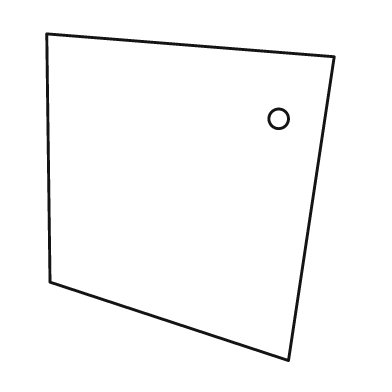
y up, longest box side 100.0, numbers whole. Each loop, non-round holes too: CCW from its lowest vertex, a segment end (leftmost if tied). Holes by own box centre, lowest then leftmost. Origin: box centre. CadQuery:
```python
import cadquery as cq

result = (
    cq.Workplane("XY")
    .moveTo(30.0, -50.0)
    .lineTo(44.0, 43.0)
    .lineTo(-44.0, 50.0)
    .lineTo(-43.0, -26.0)
    .close()
    .moveTo(27.0, 24.0)
    .circle(3.0)
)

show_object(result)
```